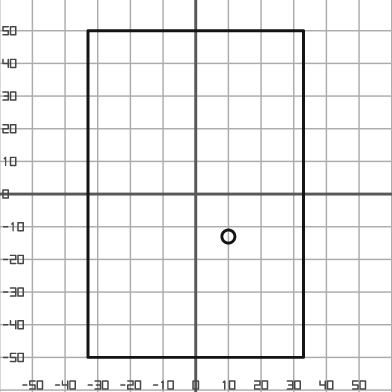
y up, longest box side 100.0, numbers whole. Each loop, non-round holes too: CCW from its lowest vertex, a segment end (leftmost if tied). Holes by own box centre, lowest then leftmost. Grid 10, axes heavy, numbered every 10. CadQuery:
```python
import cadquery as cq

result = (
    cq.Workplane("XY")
    .moveTo(-33.0, -50.0)
    .lineTo(33.0, -50.0)
    .lineTo(33.0, 50.0)
    .lineTo(-33.0, 50.0)
    .close()
    .moveTo(10.0, -13.0)
    .circle(2.0)
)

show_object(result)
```